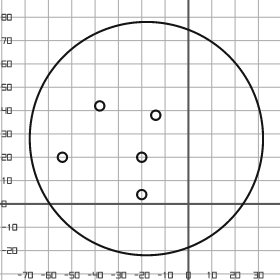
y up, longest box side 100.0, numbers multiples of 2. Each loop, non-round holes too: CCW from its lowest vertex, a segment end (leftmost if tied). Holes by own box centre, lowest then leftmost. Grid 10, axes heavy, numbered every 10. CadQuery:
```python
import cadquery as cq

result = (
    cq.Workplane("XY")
    .moveTo(-18.0, 28.0)
    .circle(50.0)
    .moveTo(-20.0, 4.0)
    .circle(2.0)
    .moveTo(-54.0, 20.0)
    .circle(2.0)
    .moveTo(-20.0, 20.0)
    .circle(2.0)
    .moveTo(-14.0, 38.0)
    .circle(2.0)
    .moveTo(-38.0, 42.0)
    .circle(2.0)
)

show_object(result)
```